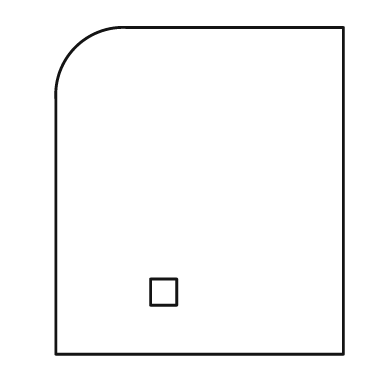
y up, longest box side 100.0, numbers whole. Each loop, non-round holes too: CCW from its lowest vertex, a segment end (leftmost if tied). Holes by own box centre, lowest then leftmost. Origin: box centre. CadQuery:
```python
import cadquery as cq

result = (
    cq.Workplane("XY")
    .moveTo(-44.0, -50.0)
    .lineTo(44.0, -50.0)
    .lineTo(44.0, 50.0)
    .lineTo(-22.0, 50.0)
    .threePointArc((-38.0, 44.0), (-44.0, 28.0))
    .close()
    .moveTo(-15.0, -35.0)
    .lineTo(-7.0, -35.0)
    .lineTo(-7.0, -27.0)
    .lineTo(-15.0, -27.0)
    .close()
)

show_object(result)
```